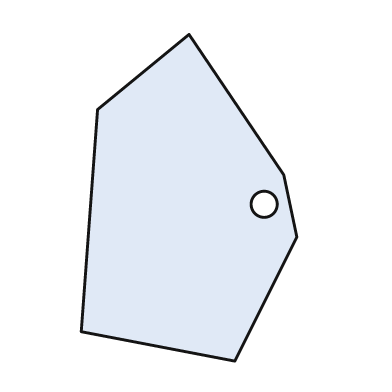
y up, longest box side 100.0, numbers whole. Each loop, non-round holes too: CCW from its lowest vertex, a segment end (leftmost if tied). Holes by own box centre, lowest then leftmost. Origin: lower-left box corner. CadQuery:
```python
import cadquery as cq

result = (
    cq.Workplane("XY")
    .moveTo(47.0, 0.0)
    .lineTo(66.0, 38.0)
    .lineTo(62.0, 57.0)
    .lineTo(33.0, 100.0)
    .lineTo(5.0, 77.0)
    .lineTo(0.0, 9.0)
    .close()
    .moveTo(56.0, 48.0)
    .circle(4.0)
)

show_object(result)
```